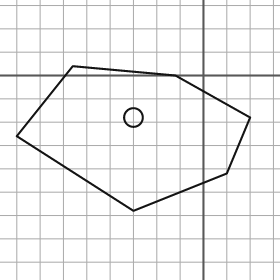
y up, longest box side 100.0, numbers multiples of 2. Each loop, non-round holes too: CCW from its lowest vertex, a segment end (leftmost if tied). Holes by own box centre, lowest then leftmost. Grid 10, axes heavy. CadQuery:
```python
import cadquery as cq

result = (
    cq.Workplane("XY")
    .moveTo(-30.0, -58.0)
    .lineTo(10.0, -42.0)
    .lineTo(20.0, -18.0)
    .lineTo(-12.0, 0.0)
    .lineTo(-56.0, 4.0)
    .lineTo(-80.0, -26.0)
    .close()
    .moveTo(-30.0, -18.0)
    .circle(4.0)
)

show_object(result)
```